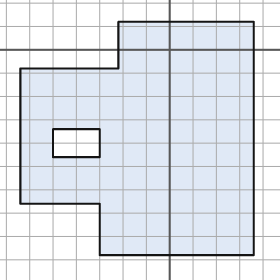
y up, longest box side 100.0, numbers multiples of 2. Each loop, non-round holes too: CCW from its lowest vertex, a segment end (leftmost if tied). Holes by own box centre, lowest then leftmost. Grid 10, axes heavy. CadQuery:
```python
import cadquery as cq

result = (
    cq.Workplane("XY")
    .moveTo(-30.0, -88.0)
    .lineTo(36.0, -88.0)
    .lineTo(36.0, 12.0)
    .lineTo(-22.0, 12.0)
    .lineTo(-22.0, -8.0)
    .lineTo(-64.0, -8.0)
    .lineTo(-64.0, -66.0)
    .lineTo(-30.0, -66.0)
    .close()
    .moveTo(-50.0, -46.0)
    .lineTo(-30.0, -46.0)
    .lineTo(-30.0, -34.0)
    .lineTo(-50.0, -34.0)
    .close()
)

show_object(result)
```